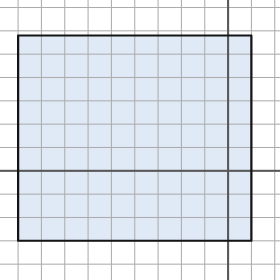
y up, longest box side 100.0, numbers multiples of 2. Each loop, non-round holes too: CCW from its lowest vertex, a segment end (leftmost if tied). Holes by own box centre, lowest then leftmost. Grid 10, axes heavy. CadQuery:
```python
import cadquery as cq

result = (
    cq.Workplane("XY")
    .moveTo(-90.0, -30.0)
    .lineTo(10.0, -30.0)
    .lineTo(10.0, 58.0)
    .lineTo(-90.0, 58.0)
    .close()
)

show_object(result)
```